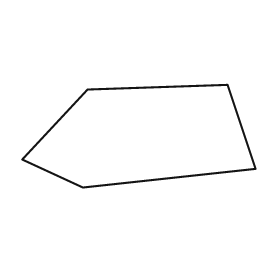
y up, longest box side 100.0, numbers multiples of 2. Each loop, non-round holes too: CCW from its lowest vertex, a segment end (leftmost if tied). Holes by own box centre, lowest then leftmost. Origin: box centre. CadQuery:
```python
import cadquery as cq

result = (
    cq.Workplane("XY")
    .moveTo(-24.0, -22.0)
    .lineTo(50.0, -14.0)
    .lineTo(38.0, 22.0)
    .lineTo(-22.0, 20.0)
    .lineTo(-50.0, -10.0)
    .close()
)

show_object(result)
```